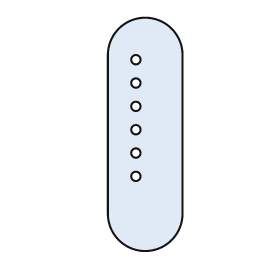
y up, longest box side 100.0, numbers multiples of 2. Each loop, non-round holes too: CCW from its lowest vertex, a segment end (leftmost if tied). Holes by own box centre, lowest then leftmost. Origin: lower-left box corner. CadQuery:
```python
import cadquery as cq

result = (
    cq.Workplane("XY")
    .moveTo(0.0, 16.0)
    .threePointArc((16.0, 0.0), (32.0, 16.0))
    .lineTo(32.0, 84.0)
    .threePointArc((16.0, 100.0), (0.0, 84.0))
    .close()
    .moveTo(12.0, 32.0)
    .circle(2.0)
    .moveTo(12.0, 42.0)
    .circle(2.0)
    .moveTo(12.0, 52.0)
    .circle(2.0)
    .moveTo(12.0, 62.0)
    .circle(2.0)
    .moveTo(12.0, 72.0)
    .circle(2.0)
    .moveTo(12.0, 82.0)
    .circle(2.0)
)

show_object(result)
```